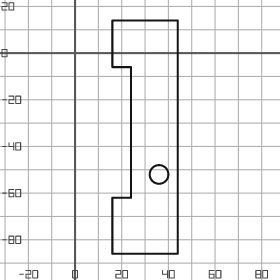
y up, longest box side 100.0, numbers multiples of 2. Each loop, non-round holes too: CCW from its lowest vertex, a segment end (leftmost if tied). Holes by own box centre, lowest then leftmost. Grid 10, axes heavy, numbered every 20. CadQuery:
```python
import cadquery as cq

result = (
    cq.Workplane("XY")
    .moveTo(16.0, -86.0)
    .lineTo(44.0, -86.0)
    .lineTo(44.0, 14.0)
    .lineTo(16.0, 14.0)
    .lineTo(16.0, -6.0)
    .lineTo(24.0, -6.0)
    .lineTo(24.0, -62.0)
    .lineTo(16.0, -62.0)
    .close()
    .moveTo(36.0, -52.0)
    .circle(4.0)
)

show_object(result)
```